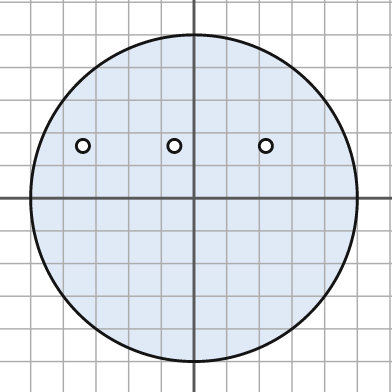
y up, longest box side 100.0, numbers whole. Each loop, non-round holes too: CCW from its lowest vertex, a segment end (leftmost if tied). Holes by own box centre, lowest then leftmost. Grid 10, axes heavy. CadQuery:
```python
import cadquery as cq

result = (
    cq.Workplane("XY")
    .moveTo(0.0, 0.0)
    .circle(50.0)
    .moveTo(-34.0, 16.0)
    .circle(2.0)
    .moveTo(-6.0, 16.0)
    .circle(2.0)
    .moveTo(22.0, 16.0)
    .circle(2.0)
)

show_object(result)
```